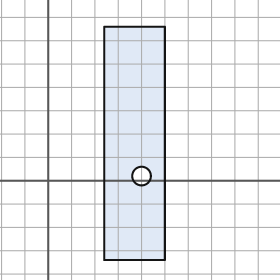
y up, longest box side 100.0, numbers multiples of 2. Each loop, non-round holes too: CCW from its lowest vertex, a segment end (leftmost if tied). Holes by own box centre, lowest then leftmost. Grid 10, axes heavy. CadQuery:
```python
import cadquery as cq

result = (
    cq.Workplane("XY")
    .moveTo(24.0, -34.0)
    .lineTo(50.0, -34.0)
    .lineTo(50.0, 66.0)
    .lineTo(24.0, 66.0)
    .close()
    .moveTo(40.0, 2.0)
    .circle(4.0)
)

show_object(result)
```